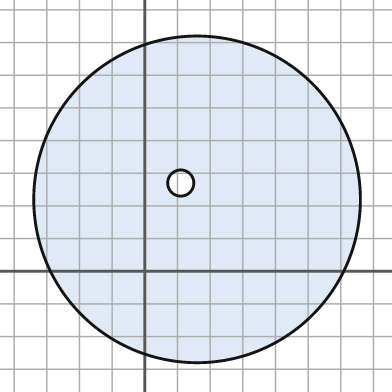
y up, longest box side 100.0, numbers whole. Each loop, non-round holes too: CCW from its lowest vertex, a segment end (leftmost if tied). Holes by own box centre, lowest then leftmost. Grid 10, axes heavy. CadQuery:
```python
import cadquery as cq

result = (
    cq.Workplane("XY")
    .moveTo(16.0, 22.0)
    .circle(50.0)
    .moveTo(11.0, 27.0)
    .circle(4.0)
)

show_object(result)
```